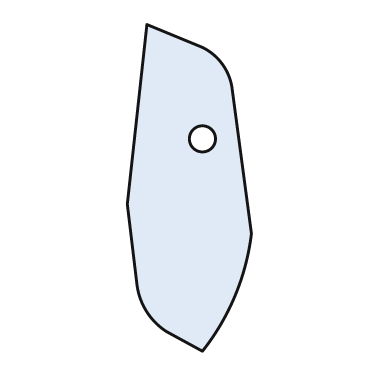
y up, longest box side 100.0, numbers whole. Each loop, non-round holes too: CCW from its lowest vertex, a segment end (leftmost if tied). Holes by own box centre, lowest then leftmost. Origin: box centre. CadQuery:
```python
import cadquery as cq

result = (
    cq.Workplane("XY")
    .moveTo(4.0, -50.0)
    .threePointArc((14.0, -33.0), (19.0, -14.0))
    .lineTo(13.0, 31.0)
    .threePointArc((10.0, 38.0), (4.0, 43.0))
    .lineTo(-13.0, 50.0)
    .lineTo(-19.0, -5.0)
    .lineTo(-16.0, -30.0)
    .threePointArc((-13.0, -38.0), (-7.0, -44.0))
    .close()
    .moveTo(4.0, 15.0)
    .circle(4.0)
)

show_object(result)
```